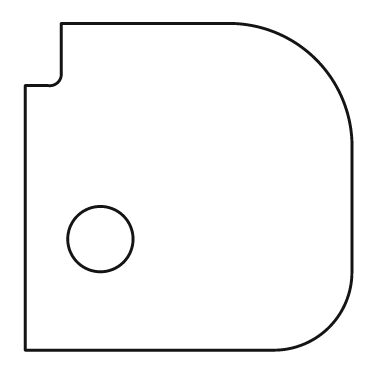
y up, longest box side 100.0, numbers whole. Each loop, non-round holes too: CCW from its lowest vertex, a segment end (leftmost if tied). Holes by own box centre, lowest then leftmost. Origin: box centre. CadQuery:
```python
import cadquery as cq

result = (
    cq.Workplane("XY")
    .moveTo(-50.0, -50.0)
    .lineTo(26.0, -50.0)
    .threePointArc((43.0, -43.0), (50.0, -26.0))
    .lineTo(50.0, 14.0)
    .threePointArc((39.0, 39.0), (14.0, 50.0))
    .lineTo(-39.0, 50.0)
    .lineTo(-39.0, 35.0)
    .threePointArc((-40.0, 32.0), (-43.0, 31.0))
    .lineTo(-50.0, 31.0)
    .close()
    .moveTo(-27.0, -16.0)
    .circle(10.0)
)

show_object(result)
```